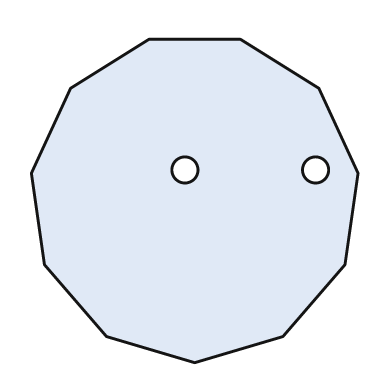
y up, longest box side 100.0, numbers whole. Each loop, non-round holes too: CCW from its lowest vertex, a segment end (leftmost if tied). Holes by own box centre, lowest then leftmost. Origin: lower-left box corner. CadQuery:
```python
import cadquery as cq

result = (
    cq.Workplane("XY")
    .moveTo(50.0, 0.0)
    .lineTo(77.0, 8.0)
    .lineTo(96.0, 30.0)
    .lineTo(100.0, 58.0)
    .lineTo(88.0, 84.0)
    .lineTo(64.0, 99.0)
    .lineTo(36.0, 99.0)
    .lineTo(12.0, 84.0)
    .lineTo(0.0, 58.0)
    .lineTo(4.0, 30.0)
    .lineTo(23.0, 8.0)
    .close()
    .moveTo(47.0, 59.0)
    .circle(4.0)
    .moveTo(87.0, 59.0)
    .circle(4.0)
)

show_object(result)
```